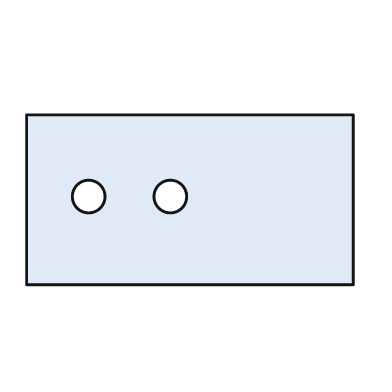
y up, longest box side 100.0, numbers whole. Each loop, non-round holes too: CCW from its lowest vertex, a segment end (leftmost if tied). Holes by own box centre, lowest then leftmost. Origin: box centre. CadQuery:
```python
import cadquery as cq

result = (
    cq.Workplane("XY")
    .moveTo(-50.0, -26.0)
    .lineTo(50.0, -26.0)
    .lineTo(50.0, 26.0)
    .lineTo(-50.0, 26.0)
    .close()
    .moveTo(-31.0, 1.0)
    .circle(5.0)
    .moveTo(-6.0, 1.0)
    .circle(5.0)
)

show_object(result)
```